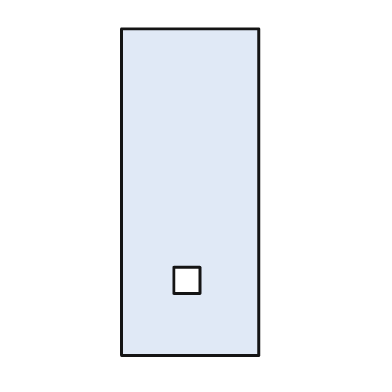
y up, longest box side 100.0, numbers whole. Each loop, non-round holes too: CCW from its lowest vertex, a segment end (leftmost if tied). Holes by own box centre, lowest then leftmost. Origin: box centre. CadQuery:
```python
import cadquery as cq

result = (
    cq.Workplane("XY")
    .moveTo(-21.0, -50.0)
    .lineTo(21.0, -50.0)
    .lineTo(21.0, 50.0)
    .lineTo(-21.0, 50.0)
    .close()
    .moveTo(-5.0, -31.0)
    .lineTo(3.0, -31.0)
    .lineTo(3.0, -23.0)
    .lineTo(-5.0, -23.0)
    .close()
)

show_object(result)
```